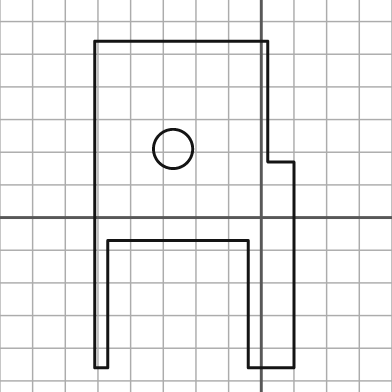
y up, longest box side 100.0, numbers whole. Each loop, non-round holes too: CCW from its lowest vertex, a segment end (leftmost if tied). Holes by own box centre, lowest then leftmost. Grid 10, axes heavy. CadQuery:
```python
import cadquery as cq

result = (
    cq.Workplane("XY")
    .moveTo(-51.0, -46.0)
    .lineTo(-47.0, -46.0)
    .lineTo(-47.0, -7.0)
    .lineTo(-4.0, -7.0)
    .lineTo(-4.0, -46.0)
    .lineTo(10.0, -46.0)
    .lineTo(10.0, 17.0)
    .lineTo(2.0, 17.0)
    .lineTo(2.0, 54.0)
    .lineTo(-51.0, 54.0)
    .close()
    .moveTo(-27.0, 21.0)
    .circle(6.0)
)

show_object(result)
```